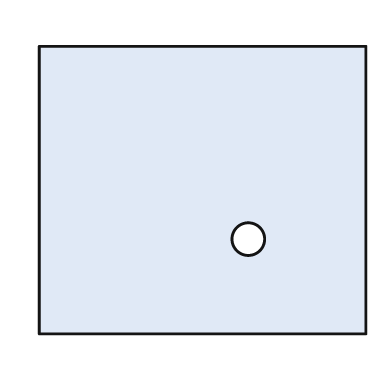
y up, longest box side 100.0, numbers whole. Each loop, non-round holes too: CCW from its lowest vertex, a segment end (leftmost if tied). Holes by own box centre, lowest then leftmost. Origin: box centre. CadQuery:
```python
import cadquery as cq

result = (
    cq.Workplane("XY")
    .moveTo(-50.0, -44.0)
    .lineTo(50.0, -44.0)
    .lineTo(50.0, 44.0)
    .lineTo(-50.0, 44.0)
    .close()
    .moveTo(14.0, -15.0)
    .circle(5.0)
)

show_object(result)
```